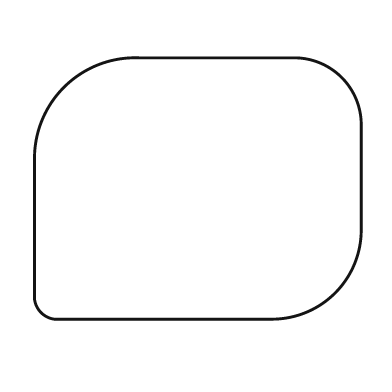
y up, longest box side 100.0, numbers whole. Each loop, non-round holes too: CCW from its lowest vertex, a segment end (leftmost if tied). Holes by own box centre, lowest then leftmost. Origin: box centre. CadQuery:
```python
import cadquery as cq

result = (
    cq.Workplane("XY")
    .moveTo(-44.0, -40.0)
    .lineTo(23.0, -40.0)
    .threePointArc((42.0, -32.0), (50.0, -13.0))
    .lineTo(50.0, 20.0)
    .threePointArc((44.0, 34.0), (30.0, 40.0))
    .lineTo(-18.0, 40.0)
    .threePointArc((-41.0, 31.0), (-50.0, 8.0))
    .lineTo(-50.0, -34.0)
    .threePointArc((-48.0, -38.0), (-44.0, -40.0))
    .close()
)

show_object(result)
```